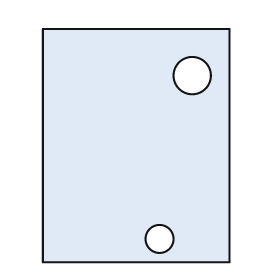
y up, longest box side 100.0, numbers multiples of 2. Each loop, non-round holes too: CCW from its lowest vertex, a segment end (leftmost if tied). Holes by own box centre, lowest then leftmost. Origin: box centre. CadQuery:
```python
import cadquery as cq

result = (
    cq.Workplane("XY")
    .moveTo(-40.0, -50.0)
    .lineTo(40.0, -50.0)
    .lineTo(40.0, 50.0)
    .lineTo(-40.0, 50.0)
    .close()
    .moveTo(10.0, -40.0)
    .circle(6.0)
    .moveTo(24.0, 30.0)
    .circle(8.0)
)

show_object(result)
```